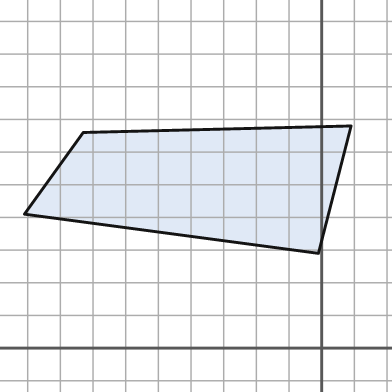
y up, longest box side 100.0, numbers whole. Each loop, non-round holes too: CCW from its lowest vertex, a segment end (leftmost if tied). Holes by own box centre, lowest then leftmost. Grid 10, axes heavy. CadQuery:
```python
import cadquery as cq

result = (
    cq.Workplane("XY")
    .moveTo(-1.0, 29.0)
    .lineTo(9.0, 68.0)
    .lineTo(-73.0, 66.0)
    .lineTo(-91.0, 41.0)
    .close()
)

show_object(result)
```